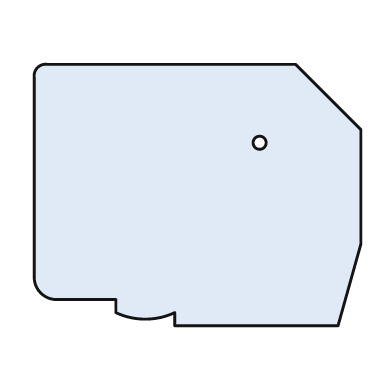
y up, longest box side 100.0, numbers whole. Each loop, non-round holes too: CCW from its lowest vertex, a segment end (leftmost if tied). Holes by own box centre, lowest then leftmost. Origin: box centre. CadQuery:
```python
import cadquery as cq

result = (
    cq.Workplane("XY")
    .moveTo(-7.0, -40.0)
    .lineTo(43.0, -40.0)
    .lineTo(50.0, -15.0)
    .lineTo(50.0, 20.0)
    .lineTo(30.0, 40.0)
    .lineTo(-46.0, 40.0)
    .threePointArc((-49.0, 39.0), (-50.0, 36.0))
    .lineTo(-50.0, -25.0)
    .threePointArc((-48.0, -30.0), (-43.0, -32.0))
    .lineTo(-25.0, -32.0)
    .lineTo(-25.0, -36.0)
    .threePointArc((-16.0, -38.0), (-7.0, -36.0))
    .close()
    .moveTo(19.0, 16.0)
    .circle(2.0)
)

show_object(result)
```